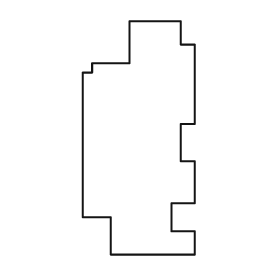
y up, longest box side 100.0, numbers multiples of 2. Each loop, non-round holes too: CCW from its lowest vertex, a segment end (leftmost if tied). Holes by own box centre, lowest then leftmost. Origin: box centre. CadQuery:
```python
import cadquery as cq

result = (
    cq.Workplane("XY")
    .moveTo(-12.0, -50.0)
    .lineTo(24.0, -50.0)
    .lineTo(24.0, -40.0)
    .lineTo(14.0, -40.0)
    .lineTo(14.0, -28.0)
    .lineTo(24.0, -28.0)
    .lineTo(24.0, -10.0)
    .lineTo(18.0, -10.0)
    .lineTo(18.0, 6.0)
    .lineTo(24.0, 6.0)
    .lineTo(24.0, 40.0)
    .lineTo(18.0, 40.0)
    .lineTo(18.0, 50.0)
    .lineTo(-4.0, 50.0)
    .lineTo(-4.0, 32.0)
    .lineTo(-20.0, 32.0)
    .lineTo(-20.0, 28.0)
    .lineTo(-24.0, 28.0)
    .lineTo(-24.0, -34.0)
    .lineTo(-12.0, -34.0)
    .close()
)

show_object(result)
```